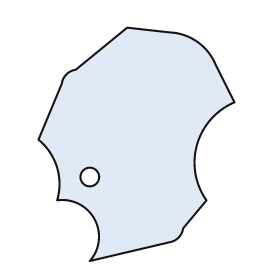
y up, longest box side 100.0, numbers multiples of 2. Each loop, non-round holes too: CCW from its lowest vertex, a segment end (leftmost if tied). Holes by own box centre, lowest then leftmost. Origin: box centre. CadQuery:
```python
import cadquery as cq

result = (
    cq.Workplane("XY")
    .moveTo(-20.0, -50.0)
    .lineTo(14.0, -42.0)
    .threePointArc((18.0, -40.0), (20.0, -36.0))
    .lineTo(30.0, -24.0)
    .threePointArc((26.0, 0.0), (42.0, 18.0))
    .lineTo(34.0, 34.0)
    .threePointArc((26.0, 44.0), (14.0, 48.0))
    .lineTo(-4.0, 50.0)
    .lineTo(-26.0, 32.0)
    .threePointArc((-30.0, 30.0), (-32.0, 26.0))
    .lineTo(-42.0, 2.0)
    .threePointArc((-34.0, -10.0), (-34.0, -24.0))
    .threePointArc((-18.0, -32.0), (-20.0, -50.0))
    .close()
    .moveTo(-20.0, -14.0)
    .circle(4.0)
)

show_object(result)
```